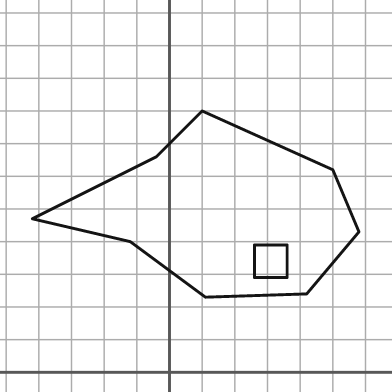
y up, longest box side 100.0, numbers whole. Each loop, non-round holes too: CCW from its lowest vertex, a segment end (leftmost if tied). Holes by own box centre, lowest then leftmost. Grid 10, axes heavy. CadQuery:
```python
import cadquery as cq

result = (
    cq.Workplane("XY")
    .moveTo(11.0, 23.0)
    .lineTo(42.0, 24.0)
    .lineTo(58.0, 43.0)
    .lineTo(50.0, 62.0)
    .lineTo(10.0, 80.0)
    .lineTo(-4.0, 66.0)
    .lineTo(-42.0, 47.0)
    .lineTo(-12.0, 40.0)
    .close()
    .moveTo(26.0, 29.0)
    .lineTo(36.0, 29.0)
    .lineTo(36.0, 39.0)
    .lineTo(26.0, 39.0)
    .close()
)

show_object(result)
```